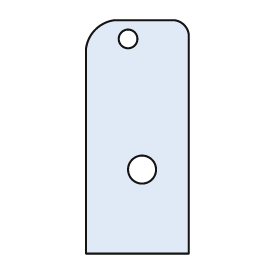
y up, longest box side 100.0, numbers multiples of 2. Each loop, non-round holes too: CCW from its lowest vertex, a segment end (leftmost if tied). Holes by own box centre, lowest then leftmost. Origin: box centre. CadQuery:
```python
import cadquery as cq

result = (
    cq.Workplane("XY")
    .moveTo(-22.0, -50.0)
    .lineTo(22.0, -50.0)
    .lineTo(22.0, 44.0)
    .threePointArc((20.0, 48.0), (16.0, 50.0))
    .lineTo(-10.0, 50.0)
    .threePointArc((-18.0, 46.0), (-22.0, 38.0))
    .close()
    .moveTo(2.0, -14.0)
    .circle(6.0)
    .moveTo(-4.0, 42.0)
    .circle(4.0)
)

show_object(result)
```